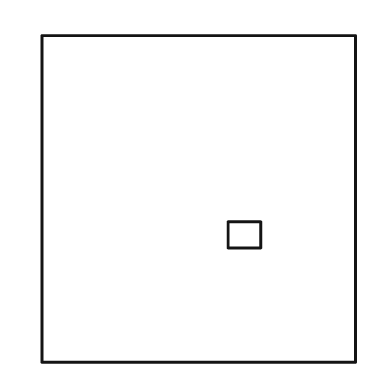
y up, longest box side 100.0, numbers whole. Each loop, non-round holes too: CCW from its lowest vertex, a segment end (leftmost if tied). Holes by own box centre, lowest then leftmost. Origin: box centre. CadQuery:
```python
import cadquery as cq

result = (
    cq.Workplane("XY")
    .moveTo(-48.0, -50.0)
    .lineTo(48.0, -50.0)
    .lineTo(48.0, 50.0)
    .lineTo(-48.0, 50.0)
    .close()
    .moveTo(9.0, -15.0)
    .lineTo(19.0, -15.0)
    .lineTo(19.0, -7.0)
    .lineTo(9.0, -7.0)
    .close()
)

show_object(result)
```